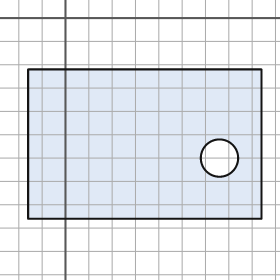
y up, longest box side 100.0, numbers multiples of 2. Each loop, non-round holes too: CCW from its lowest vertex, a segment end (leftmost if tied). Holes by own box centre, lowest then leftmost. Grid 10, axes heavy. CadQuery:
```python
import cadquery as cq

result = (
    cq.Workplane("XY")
    .moveTo(-16.0, -86.0)
    .lineTo(84.0, -86.0)
    .lineTo(84.0, -22.0)
    .lineTo(-16.0, -22.0)
    .close()
    .moveTo(66.0, -60.0)
    .circle(8.0)
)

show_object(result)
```